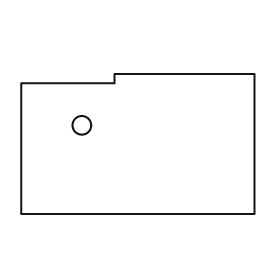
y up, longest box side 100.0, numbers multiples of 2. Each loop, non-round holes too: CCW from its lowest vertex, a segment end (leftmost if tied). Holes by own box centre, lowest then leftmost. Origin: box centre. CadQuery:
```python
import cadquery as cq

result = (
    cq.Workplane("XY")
    .moveTo(-50.0, -30.0)
    .lineTo(50.0, -30.0)
    .lineTo(50.0, 30.0)
    .lineTo(-10.0, 30.0)
    .lineTo(-10.0, 26.0)
    .lineTo(-50.0, 26.0)
    .close()
    .moveTo(-24.0, 8.0)
    .circle(4.0)
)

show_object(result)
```